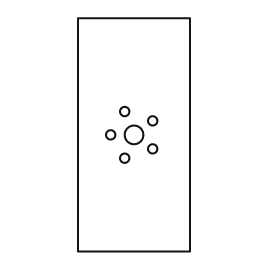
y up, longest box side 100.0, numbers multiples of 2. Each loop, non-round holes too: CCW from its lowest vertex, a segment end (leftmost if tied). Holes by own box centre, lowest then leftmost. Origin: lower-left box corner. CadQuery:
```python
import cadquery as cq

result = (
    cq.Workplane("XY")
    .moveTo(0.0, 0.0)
    .lineTo(48.0, 0.0)
    .lineTo(48.0, 100.0)
    .lineTo(0.0, 100.0)
    .close()
    .moveTo(20.0, 40.0)
    .circle(2.0)
    .moveTo(32.0, 44.0)
    .circle(2.0)
    .moveTo(14.0, 50.0)
    .circle(2.0)
    .moveTo(24.0, 50.0)
    .circle(4.0)
    .moveTo(32.0, 56.0)
    .circle(2.0)
    .moveTo(20.0, 60.0)
    .circle(2.0)
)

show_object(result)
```